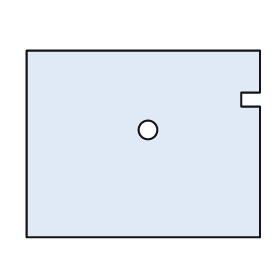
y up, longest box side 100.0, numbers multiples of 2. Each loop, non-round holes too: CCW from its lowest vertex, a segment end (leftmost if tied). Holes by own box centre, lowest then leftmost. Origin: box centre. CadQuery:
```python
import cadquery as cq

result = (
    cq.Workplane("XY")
    .moveTo(-50.0, -40.0)
    .lineTo(50.0, -40.0)
    .lineTo(50.0, 16.0)
    .lineTo(42.0, 16.0)
    .lineTo(42.0, 22.0)
    .lineTo(50.0, 22.0)
    .lineTo(50.0, 40.0)
    .lineTo(-50.0, 40.0)
    .close()
    .moveTo(2.0, 6.0)
    .circle(4.0)
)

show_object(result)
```